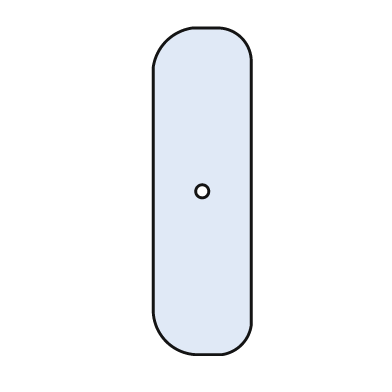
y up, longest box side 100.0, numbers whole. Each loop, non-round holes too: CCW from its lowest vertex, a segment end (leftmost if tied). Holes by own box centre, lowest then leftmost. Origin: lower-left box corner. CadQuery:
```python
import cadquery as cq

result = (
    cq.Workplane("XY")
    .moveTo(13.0, 0.0)
    .lineTo(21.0, 0.0)
    .threePointArc((27.0, 3.0), (30.0, 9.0))
    .lineTo(30.0, 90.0)
    .threePointArc((27.0, 97.0), (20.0, 100.0))
    .lineTo(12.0, 100.0)
    .threePointArc((4.0, 96.0), (0.0, 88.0))
    .lineTo(0.0, 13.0)
    .threePointArc((4.0, 4.0), (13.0, 0.0))
    .close()
    .moveTo(15.0, 50.0)
    .circle(2.0)
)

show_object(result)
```